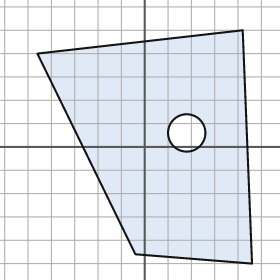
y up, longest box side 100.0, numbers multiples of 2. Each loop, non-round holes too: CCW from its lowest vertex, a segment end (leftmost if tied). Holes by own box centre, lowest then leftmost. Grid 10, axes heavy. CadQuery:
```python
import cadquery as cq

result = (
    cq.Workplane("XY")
    .moveTo(46.0, -50.0)
    .lineTo(42.0, 50.0)
    .lineTo(-46.0, 40.0)
    .lineTo(-4.0, -46.0)
    .close()
    .moveTo(18.0, 6.0)
    .circle(8.0)
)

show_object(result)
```